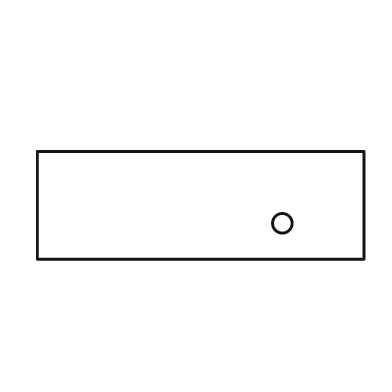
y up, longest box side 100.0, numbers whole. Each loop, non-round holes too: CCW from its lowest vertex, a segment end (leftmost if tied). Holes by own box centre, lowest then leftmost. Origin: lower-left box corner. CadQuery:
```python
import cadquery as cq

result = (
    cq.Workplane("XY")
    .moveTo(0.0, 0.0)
    .lineTo(100.0, 0.0)
    .lineTo(100.0, 33.0)
    .lineTo(0.0, 33.0)
    .close()
    .moveTo(75.0, 11.0)
    .circle(3.0)
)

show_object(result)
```